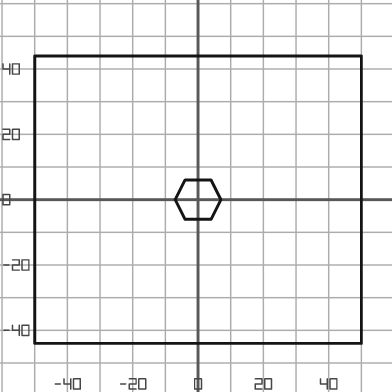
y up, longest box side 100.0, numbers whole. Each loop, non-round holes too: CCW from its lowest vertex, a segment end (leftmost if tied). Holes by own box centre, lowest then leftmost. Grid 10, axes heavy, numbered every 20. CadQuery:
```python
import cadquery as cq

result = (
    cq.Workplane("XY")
    .moveTo(-50.0, -44.0)
    .lineTo(50.0, -44.0)
    .lineTo(50.0, 44.0)
    .lineTo(-50.0, 44.0)
    .close()
    .moveTo(-4.0, -6.0)
    .lineTo(4.0, -6.0)
    .lineTo(7.0, 0.0)
    .lineTo(4.0, 6.0)
    .lineTo(-4.0, 6.0)
    .lineTo(-7.0, 0.0)
    .close()
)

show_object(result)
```